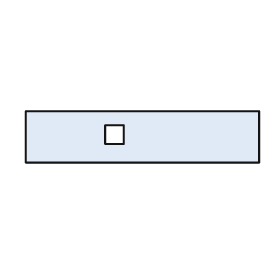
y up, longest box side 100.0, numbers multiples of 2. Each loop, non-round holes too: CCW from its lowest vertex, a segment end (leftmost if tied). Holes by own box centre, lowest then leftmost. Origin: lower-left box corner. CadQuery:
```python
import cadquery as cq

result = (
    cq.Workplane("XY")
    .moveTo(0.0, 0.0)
    .lineTo(100.0, 0.0)
    .lineTo(100.0, 22.0)
    .lineTo(0.0, 22.0)
    .close()
    .moveTo(34.0, 8.0)
    .lineTo(42.0, 8.0)
    .lineTo(42.0, 16.0)
    .lineTo(34.0, 16.0)
    .close()
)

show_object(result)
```